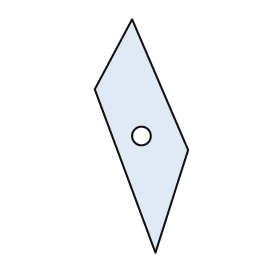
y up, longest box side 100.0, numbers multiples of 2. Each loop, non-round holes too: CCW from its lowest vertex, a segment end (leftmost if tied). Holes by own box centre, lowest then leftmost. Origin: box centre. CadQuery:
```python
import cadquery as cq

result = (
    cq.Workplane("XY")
    .moveTo(6.0, -50.0)
    .lineTo(20.0, -6.0)
    .lineTo(-4.0, 50.0)
    .lineTo(-20.0, 20.0)
    .close()
    .moveTo(0.0, 0.0)
    .circle(4.0)
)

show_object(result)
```